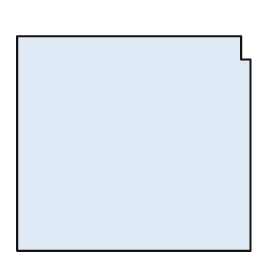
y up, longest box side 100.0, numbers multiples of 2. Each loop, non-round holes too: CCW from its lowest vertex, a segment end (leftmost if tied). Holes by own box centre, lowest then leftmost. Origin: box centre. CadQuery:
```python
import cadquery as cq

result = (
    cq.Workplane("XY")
    .moveTo(-50.0, -46.0)
    .lineTo(50.0, -46.0)
    .lineTo(50.0, 36.0)
    .lineTo(46.0, 36.0)
    .lineTo(46.0, 46.0)
    .lineTo(-50.0, 46.0)
    .close()
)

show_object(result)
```